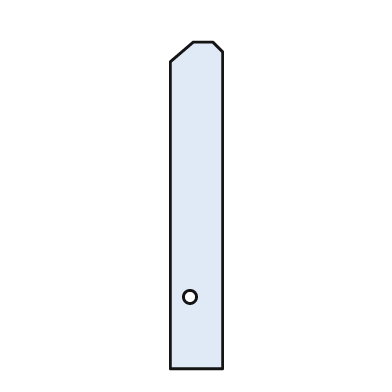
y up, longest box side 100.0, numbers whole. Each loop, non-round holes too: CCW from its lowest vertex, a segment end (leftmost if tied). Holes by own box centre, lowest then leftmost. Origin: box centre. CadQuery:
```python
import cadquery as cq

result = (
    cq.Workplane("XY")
    .moveTo(-8.0, -50.0)
    .lineTo(8.0, -50.0)
    .lineTo(8.0, 47.0)
    .lineTo(5.0, 50.0)
    .lineTo(-1.0, 50.0)
    .lineTo(-8.0, 44.0)
    .close()
    .moveTo(-2.0, -28.0)
    .circle(2.0)
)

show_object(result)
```